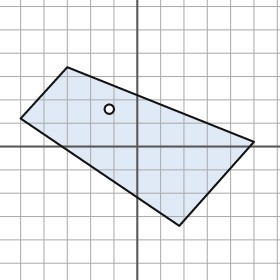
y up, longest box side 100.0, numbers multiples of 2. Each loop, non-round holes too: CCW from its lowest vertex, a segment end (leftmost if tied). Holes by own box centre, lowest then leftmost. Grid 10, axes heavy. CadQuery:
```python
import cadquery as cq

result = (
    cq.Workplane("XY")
    .moveTo(18.0, -34.0)
    .lineTo(50.0, 2.0)
    .lineTo(-30.0, 34.0)
    .lineTo(-50.0, 12.0)
    .close()
    .moveTo(-12.0, 16.0)
    .circle(2.0)
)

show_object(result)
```